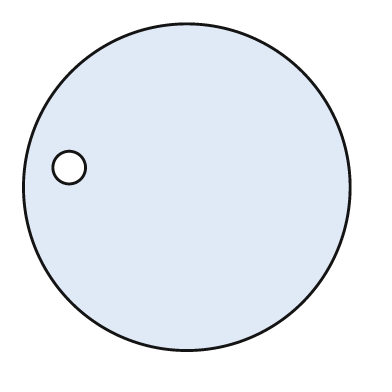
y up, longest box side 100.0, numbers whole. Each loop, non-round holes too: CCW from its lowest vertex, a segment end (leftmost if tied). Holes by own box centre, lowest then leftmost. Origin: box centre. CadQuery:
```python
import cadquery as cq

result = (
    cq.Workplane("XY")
    .moveTo(0.0, 0.0)
    .circle(50.0)
    .moveTo(-36.0, 6.0)
    .circle(5.0)
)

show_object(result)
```